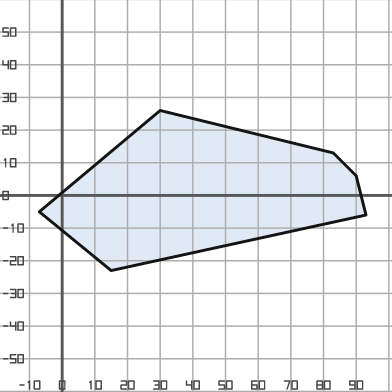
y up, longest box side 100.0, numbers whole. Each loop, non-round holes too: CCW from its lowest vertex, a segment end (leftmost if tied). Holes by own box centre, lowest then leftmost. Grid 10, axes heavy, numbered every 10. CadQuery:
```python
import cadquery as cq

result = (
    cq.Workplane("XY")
    .moveTo(15.0, -23.0)
    .lineTo(93.0, -6.0)
    .lineTo(90.0, 6.0)
    .lineTo(83.0, 13.0)
    .lineTo(30.0, 26.0)
    .lineTo(-7.0, -5.0)
    .close()
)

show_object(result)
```